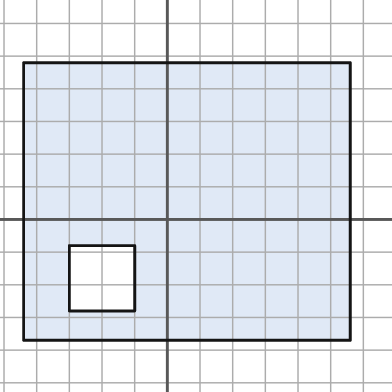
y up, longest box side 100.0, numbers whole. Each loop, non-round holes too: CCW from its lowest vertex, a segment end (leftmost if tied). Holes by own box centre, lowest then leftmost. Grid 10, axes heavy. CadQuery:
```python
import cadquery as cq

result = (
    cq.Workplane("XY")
    .moveTo(-44.0, -37.0)
    .lineTo(56.0, -37.0)
    .lineTo(56.0, 48.0)
    .lineTo(-44.0, 48.0)
    .close()
    .moveTo(-30.0, -28.0)
    .lineTo(-10.0, -28.0)
    .lineTo(-10.0, -8.0)
    .lineTo(-30.0, -8.0)
    .close()
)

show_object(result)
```